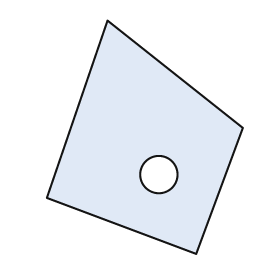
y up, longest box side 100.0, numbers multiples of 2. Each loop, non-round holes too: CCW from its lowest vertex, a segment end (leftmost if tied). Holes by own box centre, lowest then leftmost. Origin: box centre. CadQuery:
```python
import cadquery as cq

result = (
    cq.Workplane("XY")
    .moveTo(22.0, -50.0)
    .lineTo(42.0, 4.0)
    .lineTo(-16.0, 50.0)
    .lineTo(-42.0, -26.0)
    .close()
    .moveTo(6.0, -16.0)
    .circle(8.0)
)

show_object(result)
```